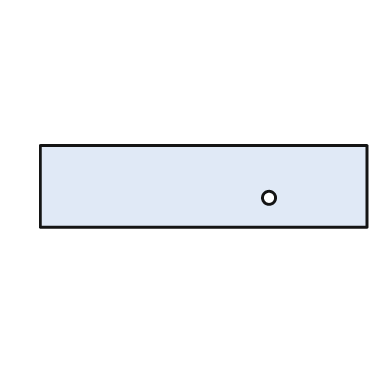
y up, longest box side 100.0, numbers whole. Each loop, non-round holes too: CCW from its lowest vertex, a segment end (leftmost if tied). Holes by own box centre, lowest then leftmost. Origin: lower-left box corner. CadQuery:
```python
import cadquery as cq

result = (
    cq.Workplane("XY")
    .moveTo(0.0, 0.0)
    .lineTo(100.0, 0.0)
    .lineTo(100.0, 25.0)
    .lineTo(0.0, 25.0)
    .close()
    .moveTo(70.0, 9.0)
    .circle(2.0)
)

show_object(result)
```